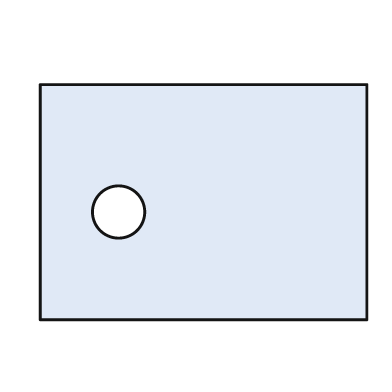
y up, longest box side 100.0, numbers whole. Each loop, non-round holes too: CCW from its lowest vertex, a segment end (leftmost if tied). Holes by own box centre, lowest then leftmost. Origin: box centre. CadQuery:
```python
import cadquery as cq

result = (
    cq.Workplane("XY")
    .moveTo(-50.0, -36.0)
    .lineTo(50.0, -36.0)
    .lineTo(50.0, 36.0)
    .lineTo(-50.0, 36.0)
    .close()
    .moveTo(-26.0, -3.0)
    .circle(8.0)
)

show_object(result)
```